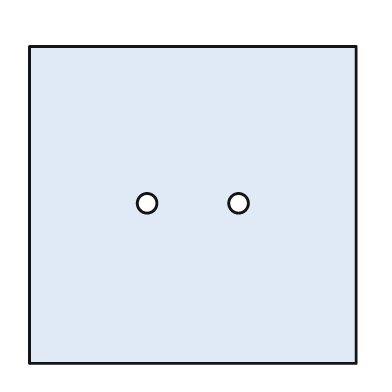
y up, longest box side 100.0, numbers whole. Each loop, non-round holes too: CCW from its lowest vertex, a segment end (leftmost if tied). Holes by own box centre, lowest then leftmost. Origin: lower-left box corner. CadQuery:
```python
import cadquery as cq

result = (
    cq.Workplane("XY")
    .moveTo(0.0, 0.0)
    .lineTo(100.0, 0.0)
    .lineTo(100.0, 97.0)
    .lineTo(0.0, 97.0)
    .close()
    .moveTo(36.0, 49.0)
    .circle(3.0)
    .moveTo(64.0, 49.0)
    .circle(3.0)
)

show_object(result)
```